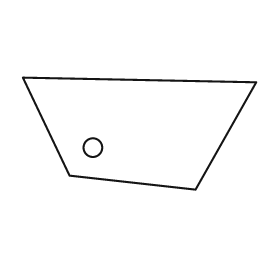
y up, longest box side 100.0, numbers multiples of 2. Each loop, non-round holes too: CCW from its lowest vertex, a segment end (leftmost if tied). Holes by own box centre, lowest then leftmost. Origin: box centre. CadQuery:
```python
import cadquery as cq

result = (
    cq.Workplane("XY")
    .moveTo(24.0, -24.0)
    .lineTo(50.0, 22.0)
    .lineTo(-50.0, 24.0)
    .lineTo(-30.0, -18.0)
    .close()
    .moveTo(-20.0, -6.0)
    .circle(4.0)
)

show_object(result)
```